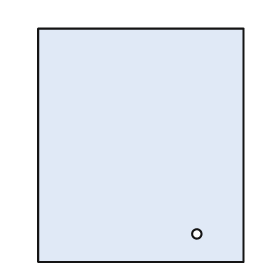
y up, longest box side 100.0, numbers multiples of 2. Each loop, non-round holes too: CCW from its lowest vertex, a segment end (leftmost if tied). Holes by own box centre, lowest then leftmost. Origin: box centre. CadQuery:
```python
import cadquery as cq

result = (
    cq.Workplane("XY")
    .moveTo(-44.0, -50.0)
    .lineTo(44.0, -50.0)
    .lineTo(44.0, 50.0)
    .lineTo(-44.0, 50.0)
    .close()
    .moveTo(24.0, -38.0)
    .circle(2.0)
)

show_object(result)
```